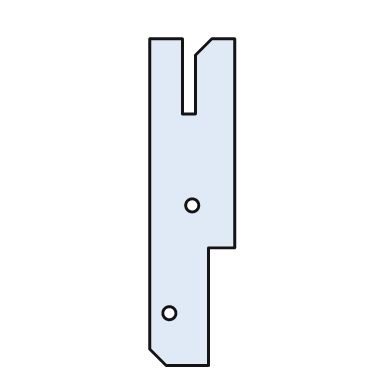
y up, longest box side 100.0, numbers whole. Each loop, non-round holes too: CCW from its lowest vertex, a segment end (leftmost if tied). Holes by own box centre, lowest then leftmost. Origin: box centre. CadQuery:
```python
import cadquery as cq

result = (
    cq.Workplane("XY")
    .moveTo(-8.0, -50.0)
    .lineTo(5.0, -50.0)
    .lineTo(5.0, -14.0)
    .lineTo(13.0, -14.0)
    .lineTo(13.0, 50.0)
    .lineTo(6.0, 50.0)
    .lineTo(1.0, 45.0)
    .lineTo(1.0, 27.0)
    .lineTo(-3.0, 27.0)
    .lineTo(-3.0, 50.0)
    .lineTo(-13.0, 50.0)
    .lineTo(-13.0, -45.0)
    .close()
    .moveTo(-7.0, -34.0)
    .circle(2.0)
    .moveTo(0.0, -1.0)
    .circle(2.0)
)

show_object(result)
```